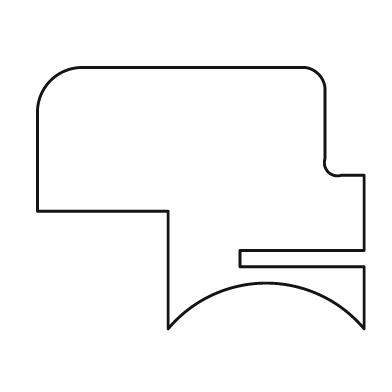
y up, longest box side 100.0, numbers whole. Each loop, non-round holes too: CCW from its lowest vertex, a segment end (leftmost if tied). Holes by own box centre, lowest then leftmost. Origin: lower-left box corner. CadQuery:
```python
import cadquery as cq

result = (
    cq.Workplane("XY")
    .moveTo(40.0, 0.0)
    .threePointArc((70.0, 14.0), (100.0, 0.0))
    .lineTo(100.0, 19.0)
    .lineTo(62.0, 19.0)
    .lineTo(62.0, 24.0)
    .lineTo(100.0, 24.0)
    .lineTo(100.0, 47.0)
    .lineTo(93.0, 47.0)
    .threePointArc((89.0, 48.0), (88.0, 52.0))
    .lineTo(88.0, 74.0)
    .threePointArc((86.0, 78.0), (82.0, 80.0))
    .lineTo(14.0, 80.0)
    .threePointArc((4.0, 76.0), (0.0, 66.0))
    .lineTo(0.0, 36.0)
    .lineTo(40.0, 36.0)
    .close()
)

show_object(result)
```